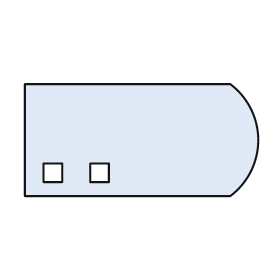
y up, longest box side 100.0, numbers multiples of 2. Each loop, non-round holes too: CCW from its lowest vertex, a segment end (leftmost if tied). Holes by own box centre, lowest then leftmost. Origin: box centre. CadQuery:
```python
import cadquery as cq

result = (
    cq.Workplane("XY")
    .moveTo(-50.0, -24.0)
    .lineTo(38.0, -24.0)
    .threePointArc((50.0, 0.0), (38.0, 24.0))
    .lineTo(-50.0, 24.0)
    .close()
    .moveTo(-42.0, -18.0)
    .lineTo(-34.0, -18.0)
    .lineTo(-34.0, -10.0)
    .lineTo(-42.0, -10.0)
    .close()
    .moveTo(-22.0, -18.0)
    .lineTo(-14.0, -18.0)
    .lineTo(-14.0, -10.0)
    .lineTo(-22.0, -10.0)
    .close()
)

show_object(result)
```